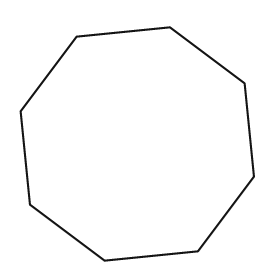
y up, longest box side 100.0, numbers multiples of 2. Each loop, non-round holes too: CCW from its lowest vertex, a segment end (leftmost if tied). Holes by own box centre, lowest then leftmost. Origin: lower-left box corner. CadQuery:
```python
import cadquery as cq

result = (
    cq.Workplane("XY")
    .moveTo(36.0, 0.0)
    .lineTo(76.0, 4.0)
    .lineTo(100.0, 36.0)
    .lineTo(96.0, 76.0)
    .lineTo(64.0, 100.0)
    .lineTo(24.0, 96.0)
    .lineTo(0.0, 64.0)
    .lineTo(4.0, 24.0)
    .close()
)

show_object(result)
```